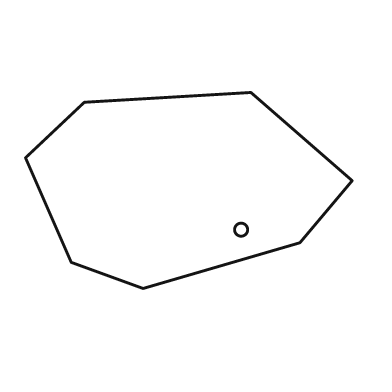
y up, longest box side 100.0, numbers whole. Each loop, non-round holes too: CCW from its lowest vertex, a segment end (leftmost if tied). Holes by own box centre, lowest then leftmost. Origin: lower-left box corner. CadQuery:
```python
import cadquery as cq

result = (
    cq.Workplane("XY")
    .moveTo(36.0, 0.0)
    .lineTo(84.0, 14.0)
    .lineTo(100.0, 33.0)
    .lineTo(69.0, 60.0)
    .lineTo(18.0, 57.0)
    .lineTo(0.0, 40.0)
    .lineTo(14.0, 8.0)
    .close()
    .moveTo(66.0, 18.0)
    .circle(2.0)
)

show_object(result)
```